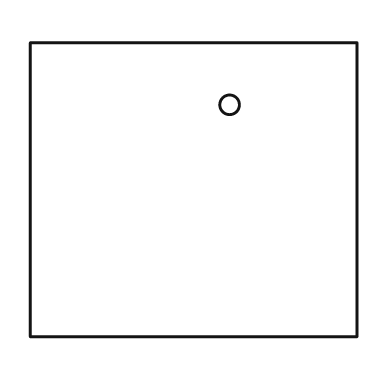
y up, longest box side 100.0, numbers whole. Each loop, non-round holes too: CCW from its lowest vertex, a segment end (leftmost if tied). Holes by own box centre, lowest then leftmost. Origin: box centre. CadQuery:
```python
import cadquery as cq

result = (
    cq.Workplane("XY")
    .moveTo(-50.0, -45.0)
    .lineTo(50.0, -45.0)
    .lineTo(50.0, 45.0)
    .lineTo(-50.0, 45.0)
    .close()
    .moveTo(11.0, 26.0)
    .circle(3.0)
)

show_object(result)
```